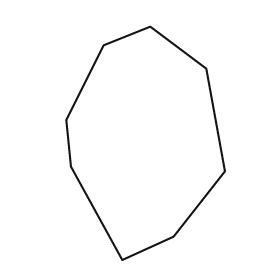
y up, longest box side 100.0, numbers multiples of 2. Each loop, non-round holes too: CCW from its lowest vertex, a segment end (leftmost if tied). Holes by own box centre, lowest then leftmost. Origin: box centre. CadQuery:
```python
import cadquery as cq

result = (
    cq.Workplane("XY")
    .moveTo(-10.0, -50.0)
    .lineTo(12.0, -40.0)
    .lineTo(34.0, -12.0)
    .lineTo(26.0, 32.0)
    .lineTo(2.0, 50.0)
    .lineTo(-18.0, 42.0)
    .lineTo(-34.0, 10.0)
    .lineTo(-32.0, -10.0)
    .close()
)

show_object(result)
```